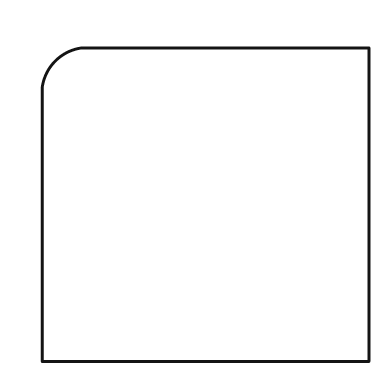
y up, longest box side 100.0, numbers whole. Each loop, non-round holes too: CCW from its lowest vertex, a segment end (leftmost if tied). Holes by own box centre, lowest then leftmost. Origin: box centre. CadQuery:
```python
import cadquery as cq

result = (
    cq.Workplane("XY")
    .moveTo(-50.0, -48.0)
    .lineTo(50.0, -48.0)
    .lineTo(50.0, 48.0)
    .lineTo(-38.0, 48.0)
    .threePointArc((-46.0, 44.0), (-50.0, 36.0))
    .close()
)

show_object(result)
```